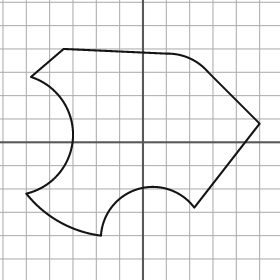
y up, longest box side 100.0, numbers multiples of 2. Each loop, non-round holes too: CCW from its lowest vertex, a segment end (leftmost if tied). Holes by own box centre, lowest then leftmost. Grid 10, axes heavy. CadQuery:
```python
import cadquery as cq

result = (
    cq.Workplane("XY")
    .moveTo(-18.0, -40.0)
    .threePointArc((-2.0, -20.0), (22.0, -28.0))
    .lineTo(50.0, 8.0)
    .lineTo(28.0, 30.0)
    .threePointArc((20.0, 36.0), (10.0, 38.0))
    .lineTo(-34.0, 40.0)
    .lineTo(-48.0, 28.0)
    .threePointArc((-30.0, 2.0), (-50.0, -22.0))
    .threePointArc((-36.0, -34.0), (-18.0, -40.0))
    .close()
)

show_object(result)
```